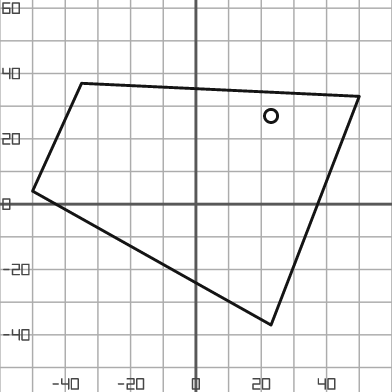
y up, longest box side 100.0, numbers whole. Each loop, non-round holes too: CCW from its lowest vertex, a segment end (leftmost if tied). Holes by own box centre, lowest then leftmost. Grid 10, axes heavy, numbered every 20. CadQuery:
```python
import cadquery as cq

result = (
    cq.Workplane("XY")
    .moveTo(23.0, -37.0)
    .lineTo(50.0, 33.0)
    .lineTo(-35.0, 37.0)
    .lineTo(-50.0, 4.0)
    .close()
    .moveTo(23.0, 27.0)
    .circle(2.0)
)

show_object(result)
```